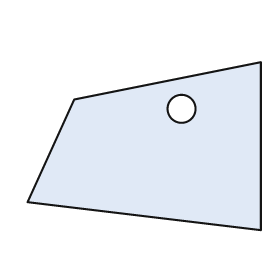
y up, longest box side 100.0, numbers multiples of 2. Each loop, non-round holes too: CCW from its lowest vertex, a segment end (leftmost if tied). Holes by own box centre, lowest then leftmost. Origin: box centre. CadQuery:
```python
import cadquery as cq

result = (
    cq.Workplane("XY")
    .moveTo(50.0, -36.0)
    .lineTo(50.0, 36.0)
    .lineTo(-30.0, 20.0)
    .lineTo(-50.0, -24.0)
    .close()
    .moveTo(16.0, 16.0)
    .circle(6.0)
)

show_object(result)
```